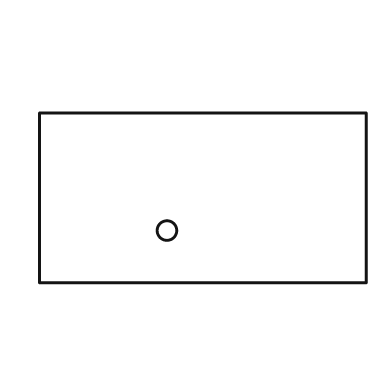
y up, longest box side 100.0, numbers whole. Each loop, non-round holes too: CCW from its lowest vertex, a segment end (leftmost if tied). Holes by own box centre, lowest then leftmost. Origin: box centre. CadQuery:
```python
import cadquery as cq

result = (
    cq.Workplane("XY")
    .moveTo(-50.0, -26.0)
    .lineTo(50.0, -26.0)
    .lineTo(50.0, 26.0)
    .lineTo(-50.0, 26.0)
    .close()
    .moveTo(-11.0, -10.0)
    .circle(3.0)
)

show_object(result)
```